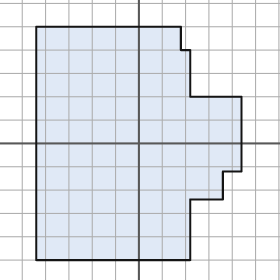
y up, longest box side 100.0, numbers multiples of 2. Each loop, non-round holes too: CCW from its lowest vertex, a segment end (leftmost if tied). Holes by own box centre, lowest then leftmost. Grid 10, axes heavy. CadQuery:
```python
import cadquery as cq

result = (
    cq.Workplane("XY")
    .moveTo(-44.0, -50.0)
    .lineTo(22.0, -50.0)
    .lineTo(22.0, -24.0)
    .lineTo(36.0, -24.0)
    .lineTo(36.0, -12.0)
    .lineTo(44.0, -12.0)
    .lineTo(44.0, 20.0)
    .lineTo(22.0, 20.0)
    .lineTo(22.0, 40.0)
    .lineTo(18.0, 40.0)
    .lineTo(18.0, 50.0)
    .lineTo(-44.0, 50.0)
    .close()
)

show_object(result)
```